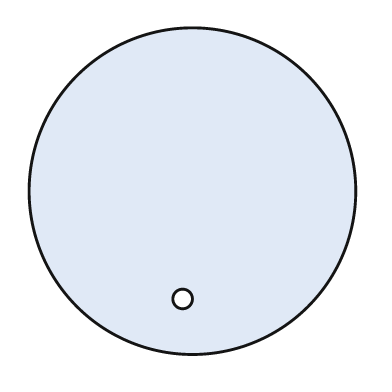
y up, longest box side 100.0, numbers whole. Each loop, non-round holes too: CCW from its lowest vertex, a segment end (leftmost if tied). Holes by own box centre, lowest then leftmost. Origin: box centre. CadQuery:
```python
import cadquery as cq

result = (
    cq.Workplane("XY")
    .moveTo(0.0, 0.0)
    .circle(50.0)
    .moveTo(-3.0, -33.0)
    .circle(3.0)
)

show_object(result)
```